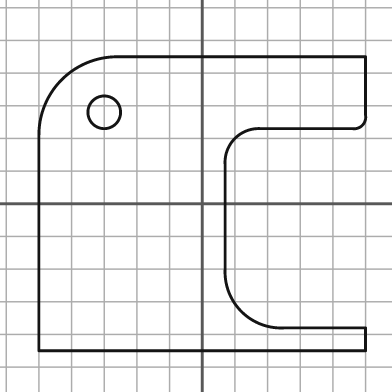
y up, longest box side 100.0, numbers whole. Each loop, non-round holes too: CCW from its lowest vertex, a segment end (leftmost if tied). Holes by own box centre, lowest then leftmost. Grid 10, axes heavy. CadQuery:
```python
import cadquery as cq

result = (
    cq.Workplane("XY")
    .moveTo(-50.0, -45.0)
    .lineTo(50.0, -45.0)
    .lineTo(50.0, -38.0)
    .lineTo(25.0, -38.0)
    .threePointArc((12.0, -33.0), (7.0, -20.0))
    .lineTo(7.0, 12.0)
    .threePointArc((10.0, 20.0), (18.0, 23.0))
    .lineTo(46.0, 23.0)
    .threePointArc((49.0, 24.0), (50.0, 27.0))
    .lineTo(50.0, 45.0)
    .lineTo(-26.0, 45.0)
    .threePointArc((-43.0, 38.0), (-50.0, 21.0))
    .close()
    .moveTo(-30.0, 28.0)
    .circle(5.0)
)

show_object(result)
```